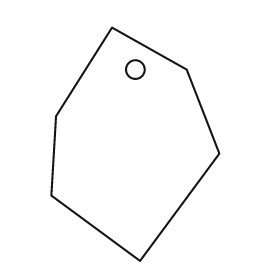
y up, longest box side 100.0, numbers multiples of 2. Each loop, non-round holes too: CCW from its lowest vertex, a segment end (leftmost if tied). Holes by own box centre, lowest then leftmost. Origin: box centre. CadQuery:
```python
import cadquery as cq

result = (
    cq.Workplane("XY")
    .moveTo(2.0, -50.0)
    .lineTo(36.0, -4.0)
    .lineTo(22.0, 32.0)
    .lineTo(-10.0, 50.0)
    .lineTo(-34.0, 12.0)
    .lineTo(-36.0, -22.0)
    .close()
    .moveTo(0.0, 32.0)
    .circle(4.0)
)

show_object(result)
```